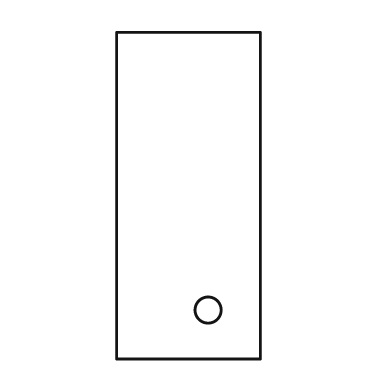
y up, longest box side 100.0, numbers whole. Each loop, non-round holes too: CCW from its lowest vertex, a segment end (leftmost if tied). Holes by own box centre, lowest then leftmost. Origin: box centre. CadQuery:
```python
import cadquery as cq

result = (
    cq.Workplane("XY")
    .moveTo(-22.0, -50.0)
    .lineTo(22.0, -50.0)
    .lineTo(22.0, 50.0)
    .lineTo(-22.0, 50.0)
    .close()
    .moveTo(6.0, -35.0)
    .circle(4.0)
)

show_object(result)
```